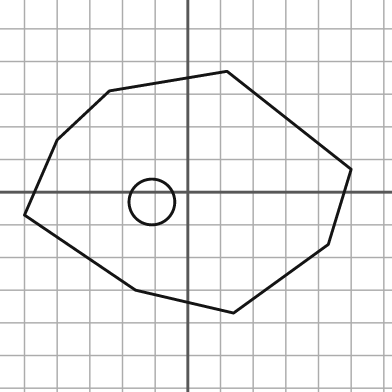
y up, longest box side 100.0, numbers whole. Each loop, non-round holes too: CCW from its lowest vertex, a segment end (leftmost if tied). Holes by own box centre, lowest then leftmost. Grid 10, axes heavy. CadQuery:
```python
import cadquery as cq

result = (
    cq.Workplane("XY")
    .moveTo(14.0, -37.0)
    .lineTo(43.0, -16.0)
    .lineTo(50.0, 7.0)
    .lineTo(12.0, 37.0)
    .lineTo(-24.0, 31.0)
    .lineTo(-40.0, 16.0)
    .lineTo(-50.0, -7.0)
    .lineTo(-16.0, -30.0)
    .close()
    .moveTo(-11.0, -3.0)
    .circle(7.0)
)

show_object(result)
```